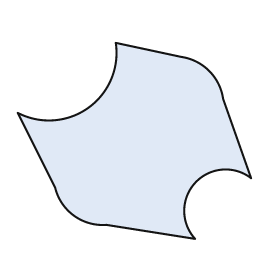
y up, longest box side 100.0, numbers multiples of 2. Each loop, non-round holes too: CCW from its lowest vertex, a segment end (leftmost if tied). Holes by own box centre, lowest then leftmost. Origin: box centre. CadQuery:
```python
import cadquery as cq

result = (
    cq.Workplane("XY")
    .moveTo(26.0, -42.0)
    .threePointArc((26.0, -18.0), (50.0, -16.0))
    .lineTo(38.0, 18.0)
    .threePointArc((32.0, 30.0), (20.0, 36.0))
    .lineTo(-8.0, 42.0)
    .threePointArc((-20.0, 14.0), (-50.0, 12.0))
    .lineTo(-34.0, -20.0)
    .threePointArc((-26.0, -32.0), (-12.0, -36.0))
    .close()
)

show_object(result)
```